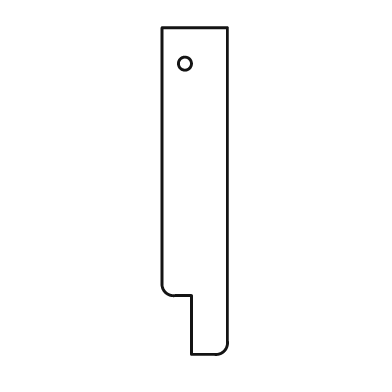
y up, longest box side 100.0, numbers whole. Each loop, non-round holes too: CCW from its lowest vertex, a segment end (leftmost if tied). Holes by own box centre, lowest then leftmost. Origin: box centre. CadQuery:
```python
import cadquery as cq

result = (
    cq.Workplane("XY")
    .moveTo(-1.0, -50.0)
    .lineTo(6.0, -50.0)
    .threePointArc((9.0, -49.0), (10.0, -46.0))
    .lineTo(10.0, 50.0)
    .lineTo(-10.0, 50.0)
    .lineTo(-10.0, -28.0)
    .threePointArc((-9.0, -31.0), (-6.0, -32.0))
    .lineTo(-1.0, -32.0)
    .close()
    .moveTo(-3.0, 39.0)
    .circle(2.0)
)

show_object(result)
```